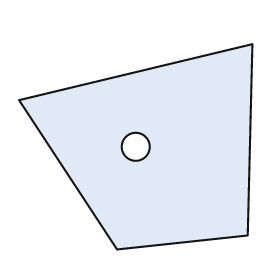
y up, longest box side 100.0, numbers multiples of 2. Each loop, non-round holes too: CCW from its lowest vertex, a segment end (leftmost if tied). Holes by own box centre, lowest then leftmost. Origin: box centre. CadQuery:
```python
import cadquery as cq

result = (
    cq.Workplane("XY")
    .moveTo(-8.0, -44.0)
    .lineTo(48.0, -38.0)
    .lineTo(50.0, 44.0)
    .lineTo(-50.0, 20.0)
    .close()
    .moveTo(0.0, 0.0)
    .circle(6.0)
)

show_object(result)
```